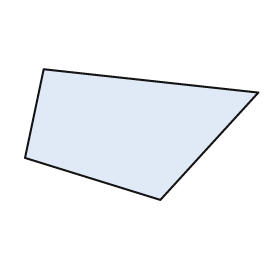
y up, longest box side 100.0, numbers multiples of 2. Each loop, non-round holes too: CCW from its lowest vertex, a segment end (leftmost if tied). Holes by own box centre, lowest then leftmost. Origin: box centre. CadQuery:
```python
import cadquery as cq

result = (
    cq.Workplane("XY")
    .moveTo(8.0, -28.0)
    .lineTo(50.0, 18.0)
    .lineTo(-42.0, 28.0)
    .lineTo(-50.0, -10.0)
    .close()
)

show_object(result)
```